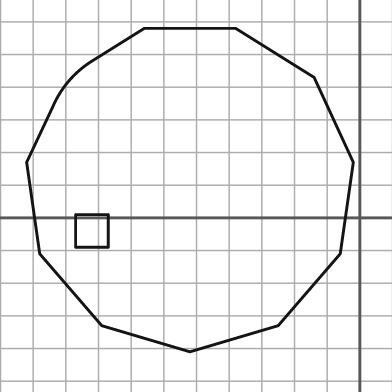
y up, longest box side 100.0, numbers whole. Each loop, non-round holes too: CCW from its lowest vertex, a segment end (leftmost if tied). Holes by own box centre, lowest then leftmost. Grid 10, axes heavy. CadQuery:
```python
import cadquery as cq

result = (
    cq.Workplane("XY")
    .moveTo(-52.0, -41.0)
    .lineTo(-25.0, -33.0)
    .lineTo(-6.0, -11.0)
    .lineTo(-2.0, 17.0)
    .lineTo(-14.0, 43.0)
    .lineTo(-38.0, 58.0)
    .lineTo(-66.0, 58.0)
    .lineTo(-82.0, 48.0)
    .threePointArc((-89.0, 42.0), (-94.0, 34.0))
    .lineTo(-102.0, 17.0)
    .lineTo(-98.0, -11.0)
    .lineTo(-79.0, -33.0)
    .close()
    .moveTo(-87.0, -9.0)
    .lineTo(-77.0, -9.0)
    .lineTo(-77.0, 1.0)
    .lineTo(-87.0, 1.0)
    .close()
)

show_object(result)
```